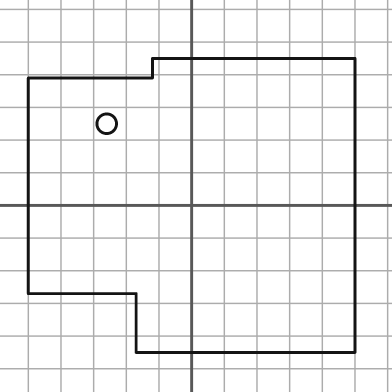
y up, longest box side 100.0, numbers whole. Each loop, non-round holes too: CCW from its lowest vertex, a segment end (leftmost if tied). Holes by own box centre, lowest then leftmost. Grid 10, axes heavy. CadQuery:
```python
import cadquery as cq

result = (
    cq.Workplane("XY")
    .moveTo(-17.0, -45.0)
    .lineTo(50.0, -45.0)
    .lineTo(50.0, 45.0)
    .lineTo(-12.0, 45.0)
    .lineTo(-12.0, 39.0)
    .lineTo(-50.0, 39.0)
    .lineTo(-50.0, -27.0)
    .lineTo(-17.0, -27.0)
    .close()
    .moveTo(-26.0, 25.0)
    .circle(3.0)
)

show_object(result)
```